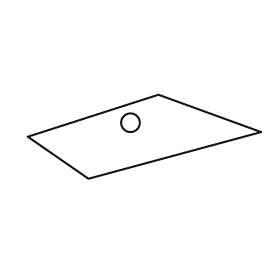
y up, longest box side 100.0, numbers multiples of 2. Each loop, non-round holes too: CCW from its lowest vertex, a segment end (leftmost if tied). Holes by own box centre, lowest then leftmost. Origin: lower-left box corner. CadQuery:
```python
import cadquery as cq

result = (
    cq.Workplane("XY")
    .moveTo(26.0, 0.0)
    .lineTo(100.0, 20.0)
    .lineTo(56.0, 36.0)
    .lineTo(0.0, 18.0)
    .close()
    .moveTo(44.0, 24.0)
    .circle(4.0)
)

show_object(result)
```